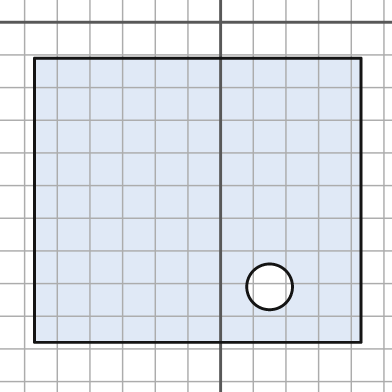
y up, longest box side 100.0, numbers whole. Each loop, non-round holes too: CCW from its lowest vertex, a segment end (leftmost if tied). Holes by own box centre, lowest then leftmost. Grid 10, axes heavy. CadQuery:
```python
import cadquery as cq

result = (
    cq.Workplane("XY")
    .moveTo(-57.0, -98.0)
    .lineTo(43.0, -98.0)
    .lineTo(43.0, -11.0)
    .lineTo(-57.0, -11.0)
    .close()
    .moveTo(15.0, -81.0)
    .circle(7.0)
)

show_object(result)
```